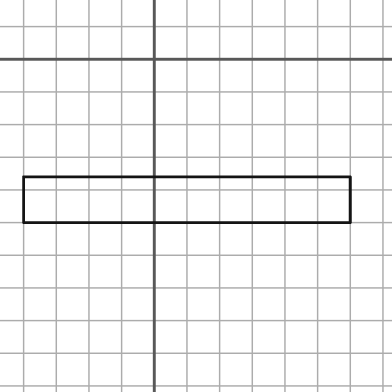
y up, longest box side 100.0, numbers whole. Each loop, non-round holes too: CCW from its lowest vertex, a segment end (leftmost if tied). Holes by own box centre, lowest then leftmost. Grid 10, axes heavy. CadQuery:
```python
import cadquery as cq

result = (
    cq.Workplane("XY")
    .moveTo(-40.0, -50.0)
    .lineTo(60.0, -50.0)
    .lineTo(60.0, -36.0)
    .lineTo(-40.0, -36.0)
    .close()
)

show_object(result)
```